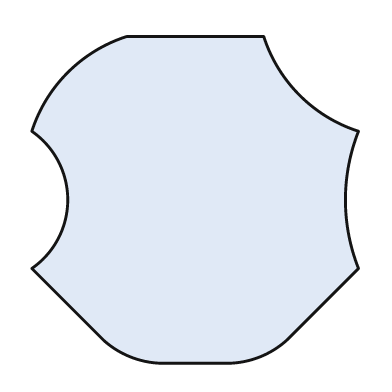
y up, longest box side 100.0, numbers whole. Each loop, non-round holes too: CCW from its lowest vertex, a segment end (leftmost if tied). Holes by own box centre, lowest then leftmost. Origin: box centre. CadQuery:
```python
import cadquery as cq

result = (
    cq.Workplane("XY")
    .moveTo(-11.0, -50.0)
    .lineTo(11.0, -50.0)
    .threePointArc((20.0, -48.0), (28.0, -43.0))
    .lineTo(50.0, -21.0)
    .threePointArc((46.0, 0.0), (50.0, 21.0))
    .threePointArc((32.0, 32.0), (21.0, 50.0))
    .lineTo(-21.0, 50.0)
    .threePointArc((-39.0, 39.0), (-50.0, 21.0))
    .threePointArc((-39.0, 0.0), (-50.0, -21.0))
    .lineTo(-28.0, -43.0)
    .threePointArc((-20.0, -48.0), (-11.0, -50.0))
    .close()
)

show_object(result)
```